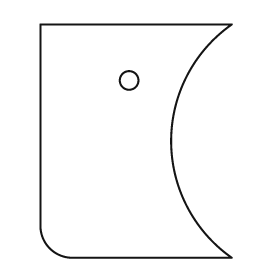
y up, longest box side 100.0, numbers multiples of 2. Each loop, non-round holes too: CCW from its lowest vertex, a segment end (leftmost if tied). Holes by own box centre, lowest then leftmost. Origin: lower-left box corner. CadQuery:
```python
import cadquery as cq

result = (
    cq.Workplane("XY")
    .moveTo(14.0, 0.0)
    .lineTo(82.0, 0.0)
    .threePointArc((56.0, 50.0), (82.0, 100.0))
    .lineTo(0.0, 100.0)
    .lineTo(0.0, 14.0)
    .threePointArc((4.0, 4.0), (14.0, 0.0))
    .close()
    .moveTo(38.0, 76.0)
    .circle(4.0)
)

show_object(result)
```